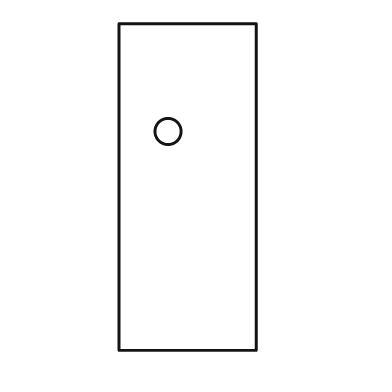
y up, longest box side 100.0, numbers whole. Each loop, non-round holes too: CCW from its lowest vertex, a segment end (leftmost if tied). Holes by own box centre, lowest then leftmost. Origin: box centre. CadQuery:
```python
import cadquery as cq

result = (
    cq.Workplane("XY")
    .moveTo(-21.0, -50.0)
    .lineTo(21.0, -50.0)
    .lineTo(21.0, 50.0)
    .lineTo(-21.0, 50.0)
    .close()
    .moveTo(-6.0, 17.0)
    .circle(4.0)
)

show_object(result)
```